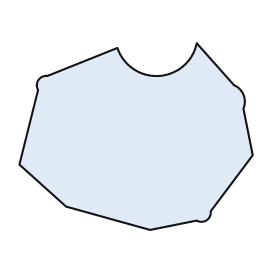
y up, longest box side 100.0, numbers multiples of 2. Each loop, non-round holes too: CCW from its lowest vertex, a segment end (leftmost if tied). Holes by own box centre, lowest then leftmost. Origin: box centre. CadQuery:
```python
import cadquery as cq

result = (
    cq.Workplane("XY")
    .moveTo(6.0, -40.0)
    .lineTo(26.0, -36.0)
    .threePointArc((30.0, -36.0), (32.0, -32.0))
    .lineTo(50.0, -8.0)
    .lineTo(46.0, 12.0)
    .threePointArc((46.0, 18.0), (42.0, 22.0))
    .lineTo(26.0, 40.0)
    .threePointArc((10.0, 26.0), (-8.0, 38.0))
    .lineTo(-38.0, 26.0)
    .threePointArc((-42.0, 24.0), (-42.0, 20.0))
    .lineTo(-50.0, -12.0)
    .lineTo(-30.0, -30.0)
    .close()
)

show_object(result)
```